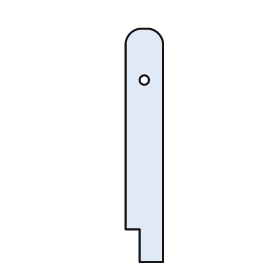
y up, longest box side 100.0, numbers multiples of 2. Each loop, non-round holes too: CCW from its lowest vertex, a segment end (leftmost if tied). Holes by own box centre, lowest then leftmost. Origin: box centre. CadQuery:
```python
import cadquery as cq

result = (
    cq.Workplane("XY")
    .moveTo(-2.0, -50.0)
    .lineTo(8.0, -50.0)
    .lineTo(8.0, 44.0)
    .threePointArc((6.0, 48.0), (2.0, 50.0))
    .lineTo(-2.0, 50.0)
    .threePointArc((-6.0, 48.0), (-8.0, 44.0))
    .lineTo(-8.0, -36.0)
    .lineTo(-2.0, -36.0)
    .close()
    .moveTo(0.0, 28.0)
    .circle(2.0)
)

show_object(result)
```